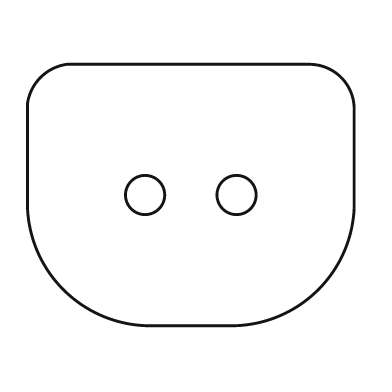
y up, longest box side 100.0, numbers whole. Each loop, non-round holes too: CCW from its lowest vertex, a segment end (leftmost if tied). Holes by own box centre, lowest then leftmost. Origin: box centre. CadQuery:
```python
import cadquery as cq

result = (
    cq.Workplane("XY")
    .moveTo(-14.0, -40.0)
    .lineTo(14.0, -40.0)
    .threePointArc((39.0, -29.0), (50.0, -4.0))
    .lineTo(50.0, 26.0)
    .threePointArc((46.0, 36.0), (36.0, 40.0))
    .lineTo(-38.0, 40.0)
    .threePointArc((-46.0, 36.0), (-50.0, 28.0))
    .lineTo(-50.0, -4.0)
    .threePointArc((-39.0, -29.0), (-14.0, -40.0))
    .close()
    .moveTo(-14.0, 0.0)
    .circle(6.0)
    .moveTo(14.0, 0.0)
    .circle(6.0)
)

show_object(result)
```